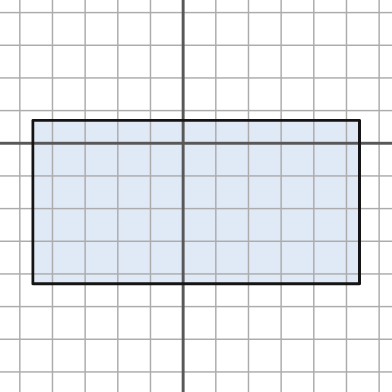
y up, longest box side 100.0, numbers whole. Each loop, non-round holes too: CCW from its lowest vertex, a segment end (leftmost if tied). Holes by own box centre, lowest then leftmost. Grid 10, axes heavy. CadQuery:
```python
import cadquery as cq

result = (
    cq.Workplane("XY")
    .moveTo(-46.0, -43.0)
    .lineTo(54.0, -43.0)
    .lineTo(54.0, 7.0)
    .lineTo(-46.0, 7.0)
    .close()
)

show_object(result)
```